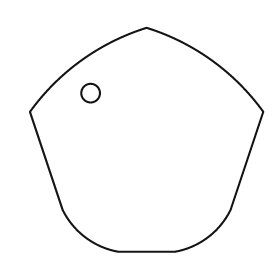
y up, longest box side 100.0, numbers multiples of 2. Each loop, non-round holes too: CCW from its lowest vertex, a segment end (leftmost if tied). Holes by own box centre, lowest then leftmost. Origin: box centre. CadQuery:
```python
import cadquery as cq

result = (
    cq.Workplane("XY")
    .moveTo(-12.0, -48.0)
    .lineTo(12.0, -48.0)
    .threePointArc((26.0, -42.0), (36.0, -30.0))
    .lineTo(50.0, 12.0)
    .threePointArc((28.0, 34.0), (0.0, 48.0))
    .threePointArc((-28.0, 34.0), (-50.0, 12.0))
    .lineTo(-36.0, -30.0)
    .threePointArc((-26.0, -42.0), (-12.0, -48.0))
    .close()
    .moveTo(-24.0, 20.0)
    .circle(4.0)
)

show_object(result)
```